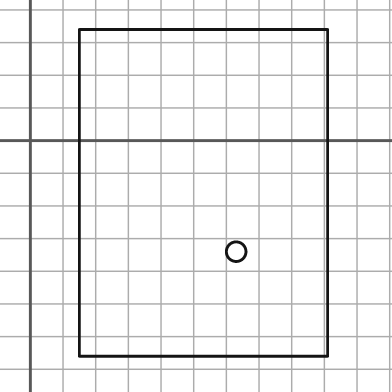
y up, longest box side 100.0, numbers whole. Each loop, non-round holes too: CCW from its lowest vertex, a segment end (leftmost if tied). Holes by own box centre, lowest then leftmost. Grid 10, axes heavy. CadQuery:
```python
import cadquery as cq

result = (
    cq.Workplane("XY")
    .moveTo(15.0, -66.0)
    .lineTo(91.0, -66.0)
    .lineTo(91.0, 34.0)
    .lineTo(15.0, 34.0)
    .close()
    .moveTo(63.0, -34.0)
    .circle(3.0)
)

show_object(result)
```